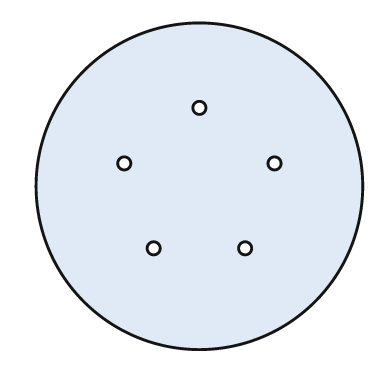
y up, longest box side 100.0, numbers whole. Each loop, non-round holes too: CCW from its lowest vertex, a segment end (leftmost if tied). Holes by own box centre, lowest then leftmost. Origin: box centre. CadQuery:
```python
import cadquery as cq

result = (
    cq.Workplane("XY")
    .moveTo(0.0, 0.0)
    .circle(50.0)
    .moveTo(-14.0, -19.0)
    .circle(2.0)
    .moveTo(14.0, -19.0)
    .circle(2.0)
    .moveTo(-23.0, 7.0)
    .circle(2.0)
    .moveTo(23.0, 7.0)
    .circle(2.0)
    .moveTo(0.0, 24.0)
    .circle(2.0)
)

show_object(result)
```